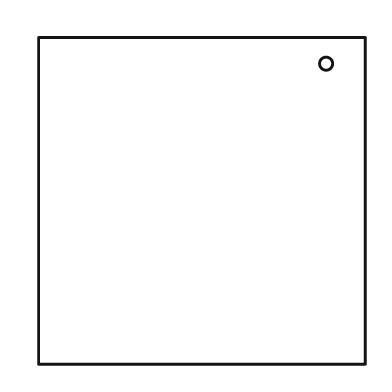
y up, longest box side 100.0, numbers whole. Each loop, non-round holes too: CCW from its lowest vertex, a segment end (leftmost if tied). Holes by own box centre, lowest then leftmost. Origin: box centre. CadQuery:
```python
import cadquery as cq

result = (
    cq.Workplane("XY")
    .moveTo(-50.0, -50.0)
    .lineTo(50.0, -50.0)
    .lineTo(50.0, 50.0)
    .lineTo(-50.0, 50.0)
    .close()
    .moveTo(38.0, 42.0)
    .circle(2.0)
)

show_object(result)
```